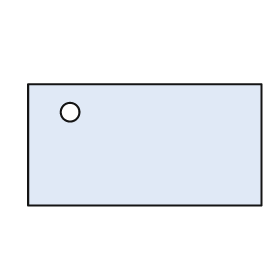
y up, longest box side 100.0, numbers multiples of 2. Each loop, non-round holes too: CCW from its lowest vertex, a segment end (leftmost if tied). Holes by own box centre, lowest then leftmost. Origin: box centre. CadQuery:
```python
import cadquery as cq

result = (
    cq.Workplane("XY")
    .moveTo(-50.0, -26.0)
    .lineTo(50.0, -26.0)
    .lineTo(50.0, 26.0)
    .lineTo(-50.0, 26.0)
    .close()
    .moveTo(-32.0, 14.0)
    .circle(4.0)
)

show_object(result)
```